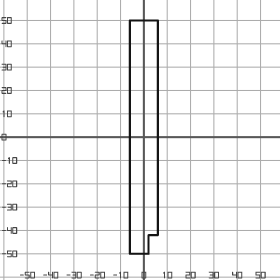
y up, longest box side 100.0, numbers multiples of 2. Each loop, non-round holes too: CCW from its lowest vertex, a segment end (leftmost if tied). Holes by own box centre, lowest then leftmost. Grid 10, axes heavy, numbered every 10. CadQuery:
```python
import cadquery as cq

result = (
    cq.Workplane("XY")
    .moveTo(-6.0, -50.0)
    .lineTo(2.0, -50.0)
    .lineTo(2.0, -42.0)
    .lineTo(6.0, -42.0)
    .lineTo(6.0, 50.0)
    .lineTo(-6.0, 50.0)
    .close()
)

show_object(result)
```